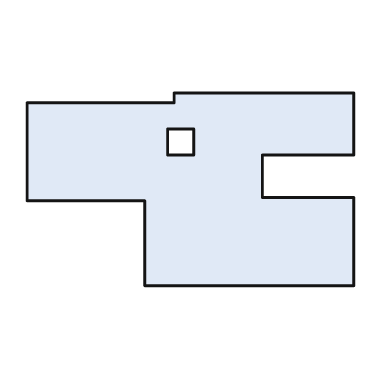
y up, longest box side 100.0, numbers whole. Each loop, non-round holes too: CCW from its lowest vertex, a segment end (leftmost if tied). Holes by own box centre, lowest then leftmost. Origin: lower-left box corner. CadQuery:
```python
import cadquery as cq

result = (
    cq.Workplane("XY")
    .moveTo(36.0, 0.0)
    .lineTo(100.0, 0.0)
    .lineTo(100.0, 27.0)
    .lineTo(72.0, 27.0)
    .lineTo(72.0, 40.0)
    .lineTo(100.0, 40.0)
    .lineTo(100.0, 59.0)
    .lineTo(45.0, 59.0)
    .lineTo(45.0, 56.0)
    .lineTo(0.0, 56.0)
    .lineTo(0.0, 26.0)
    .lineTo(36.0, 26.0)
    .close()
    .moveTo(43.0, 40.0)
    .lineTo(51.0, 40.0)
    .lineTo(51.0, 48.0)
    .lineTo(43.0, 48.0)
    .close()
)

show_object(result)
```